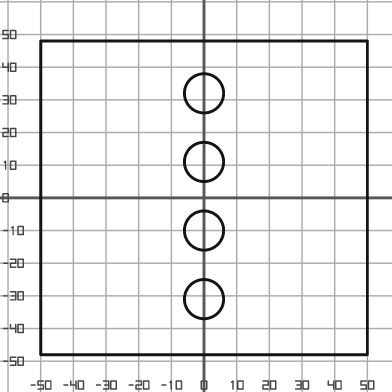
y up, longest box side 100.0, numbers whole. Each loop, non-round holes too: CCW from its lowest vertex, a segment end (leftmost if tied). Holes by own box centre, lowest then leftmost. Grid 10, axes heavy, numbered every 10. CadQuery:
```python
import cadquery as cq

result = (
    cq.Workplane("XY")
    .moveTo(-50.0, -48.0)
    .lineTo(50.0, -48.0)
    .lineTo(50.0, 48.0)
    .lineTo(-50.0, 48.0)
    .close()
    .moveTo(0.0, -31.0)
    .circle(6.0)
    .moveTo(0.0, -10.0)
    .circle(6.0)
    .moveTo(0.0, 11.0)
    .circle(6.0)
    .moveTo(0.0, 32.0)
    .circle(6.0)
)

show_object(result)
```